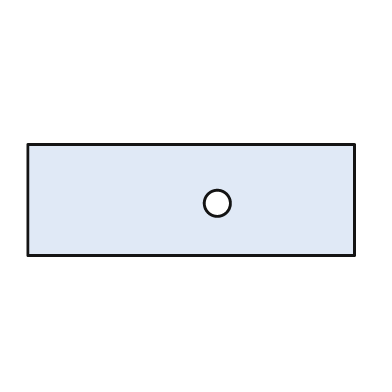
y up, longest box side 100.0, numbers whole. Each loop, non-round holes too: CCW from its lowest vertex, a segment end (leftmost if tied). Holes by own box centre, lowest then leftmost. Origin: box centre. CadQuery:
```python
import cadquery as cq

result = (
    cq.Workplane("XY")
    .moveTo(-50.0, -17.0)
    .lineTo(50.0, -17.0)
    .lineTo(50.0, 17.0)
    .lineTo(-50.0, 17.0)
    .close()
    .moveTo(8.0, -1.0)
    .circle(4.0)
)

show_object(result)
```